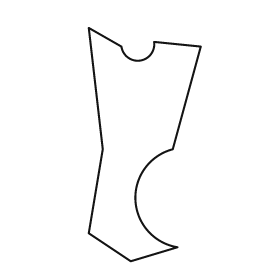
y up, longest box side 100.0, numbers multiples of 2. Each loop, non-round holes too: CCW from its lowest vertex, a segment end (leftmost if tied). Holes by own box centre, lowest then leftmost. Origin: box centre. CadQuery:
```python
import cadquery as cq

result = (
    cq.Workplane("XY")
    .moveTo(-6.0, -50.0)
    .lineTo(14.0, -44.0)
    .threePointArc((-4.0, -24.0), (12.0, -2.0))
    .lineTo(24.0, 42.0)
    .lineTo(4.0, 44.0)
    .threePointArc((-2.0, 36.0), (-10.0, 42.0))
    .lineTo(-24.0, 50.0)
    .lineTo(-18.0, -2.0)
    .lineTo(-24.0, -38.0)
    .close()
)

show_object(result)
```